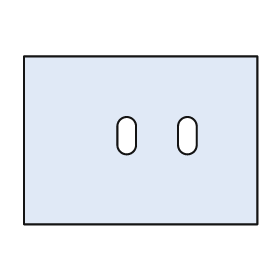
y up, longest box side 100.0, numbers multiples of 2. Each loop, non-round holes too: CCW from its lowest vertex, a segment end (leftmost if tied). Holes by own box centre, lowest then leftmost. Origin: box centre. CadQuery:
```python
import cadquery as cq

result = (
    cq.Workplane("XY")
    .moveTo(-50.0, -36.0)
    .lineTo(50.0, -36.0)
    .lineTo(50.0, 36.0)
    .lineTo(-50.0, 36.0)
    .close()
    .moveTo(-10.0, -2.0)
    .threePointArc((-6.0, -6.0), (-2.0, -2.0))
    .lineTo(-2.0, 6.0)
    .threePointArc((-6.0, 10.0), (-10.0, 6.0))
    .close()
    .moveTo(16.0, -2.0)
    .threePointArc((20.0, -6.0), (24.0, -2.0))
    .lineTo(24.0, 6.0)
    .threePointArc((20.0, 10.0), (16.0, 6.0))
    .close()
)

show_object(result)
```